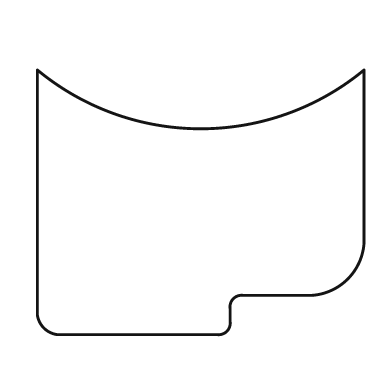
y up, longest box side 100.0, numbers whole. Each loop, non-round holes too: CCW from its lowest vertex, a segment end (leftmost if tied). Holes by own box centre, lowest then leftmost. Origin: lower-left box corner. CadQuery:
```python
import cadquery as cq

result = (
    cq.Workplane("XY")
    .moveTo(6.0, 0.0)
    .lineTo(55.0, 0.0)
    .threePointArc((58.0, 1.0), (59.0, 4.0))
    .lineTo(59.0, 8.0)
    .threePointArc((60.0, 11.0), (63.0, 12.0))
    .lineTo(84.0, 12.0)
    .threePointArc((95.0, 17.0), (100.0, 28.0))
    .lineTo(100.0, 81.0)
    .threePointArc((50.0, 63.0), (0.0, 81.0))
    .lineTo(0.0, 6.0)
    .threePointArc((2.0, 2.0), (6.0, 0.0))
    .close()
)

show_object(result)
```